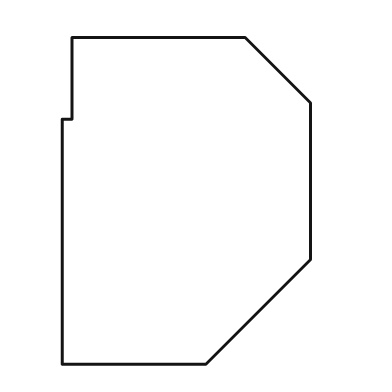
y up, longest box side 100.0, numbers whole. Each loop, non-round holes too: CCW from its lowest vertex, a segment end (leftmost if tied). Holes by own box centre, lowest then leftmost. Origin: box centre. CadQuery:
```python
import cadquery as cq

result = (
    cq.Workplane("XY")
    .moveTo(-38.0, -50.0)
    .lineTo(6.0, -50.0)
    .lineTo(38.0, -18.0)
    .lineTo(38.0, 30.0)
    .lineTo(18.0, 50.0)
    .lineTo(-35.0, 50.0)
    .lineTo(-35.0, 25.0)
    .lineTo(-38.0, 25.0)
    .close()
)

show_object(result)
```